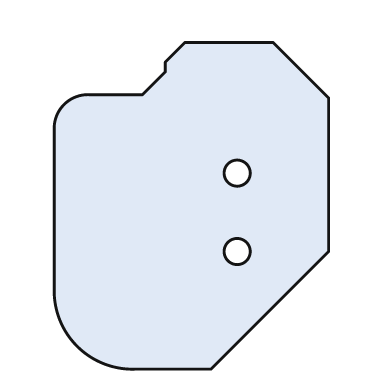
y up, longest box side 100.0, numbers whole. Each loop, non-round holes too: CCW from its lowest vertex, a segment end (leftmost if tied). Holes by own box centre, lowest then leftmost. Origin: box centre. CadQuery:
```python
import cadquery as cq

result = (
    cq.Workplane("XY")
    .moveTo(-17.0, -50.0)
    .lineTo(6.0, -50.0)
    .lineTo(42.0, -14.0)
    .lineTo(42.0, 33.0)
    .lineTo(25.0, 50.0)
    .lineTo(-2.0, 50.0)
    .lineTo(-8.0, 44.0)
    .lineTo(-8.0, 41.0)
    .lineTo(-15.0, 34.0)
    .lineTo(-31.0, 34.0)
    .threePointArc((-39.0, 31.0), (-42.0, 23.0))
    .lineTo(-42.0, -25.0)
    .threePointArc((-35.0, -43.0), (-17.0, -50.0))
    .close()
    .moveTo(14.0, -14.0)
    .circle(4.0)
    .moveTo(14.0, 10.0)
    .circle(4.0)
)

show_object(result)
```